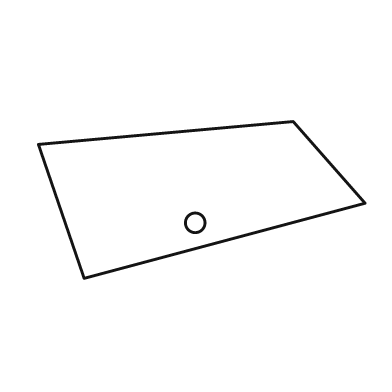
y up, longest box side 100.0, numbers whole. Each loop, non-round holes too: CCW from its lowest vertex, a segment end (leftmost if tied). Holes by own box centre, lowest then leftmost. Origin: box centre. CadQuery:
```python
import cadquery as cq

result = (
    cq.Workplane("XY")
    .moveTo(-36.0, -24.0)
    .lineTo(50.0, -1.0)
    .lineTo(28.0, 24.0)
    .lineTo(-50.0, 17.0)
    .close()
    .moveTo(-2.0, -7.0)
    .circle(3.0)
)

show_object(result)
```